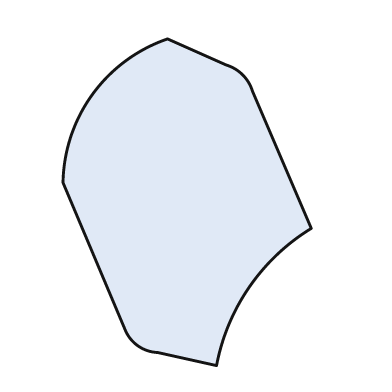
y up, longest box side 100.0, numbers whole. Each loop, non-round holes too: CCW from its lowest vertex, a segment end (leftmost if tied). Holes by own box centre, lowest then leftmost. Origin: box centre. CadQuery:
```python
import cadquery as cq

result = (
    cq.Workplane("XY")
    .moveTo(9.0, -50.0)
    .threePointArc((19.0, -26.0), (38.0, -8.0))
    .lineTo(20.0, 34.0)
    .threePointArc((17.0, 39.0), (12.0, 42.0))
    .lineTo(-6.0, 50.0)
    .threePointArc((-29.0, 33.0), (-38.0, 6.0))
    .lineTo(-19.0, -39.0)
    .threePointArc((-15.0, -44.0), (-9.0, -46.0))
    .close()
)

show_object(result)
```